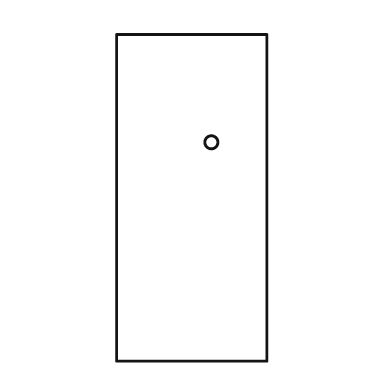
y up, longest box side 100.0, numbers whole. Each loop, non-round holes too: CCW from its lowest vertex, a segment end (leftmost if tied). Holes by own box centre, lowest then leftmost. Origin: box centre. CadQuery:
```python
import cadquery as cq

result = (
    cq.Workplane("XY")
    .moveTo(-23.0, -50.0)
    .lineTo(23.0, -50.0)
    .lineTo(23.0, 50.0)
    .lineTo(-23.0, 50.0)
    .close()
    .moveTo(6.0, 17.0)
    .circle(2.0)
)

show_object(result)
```